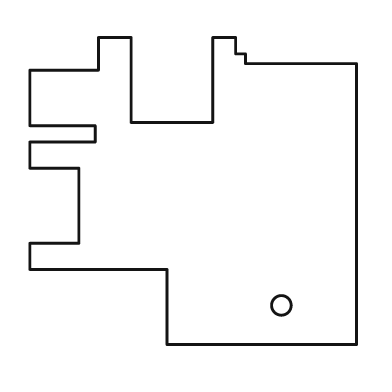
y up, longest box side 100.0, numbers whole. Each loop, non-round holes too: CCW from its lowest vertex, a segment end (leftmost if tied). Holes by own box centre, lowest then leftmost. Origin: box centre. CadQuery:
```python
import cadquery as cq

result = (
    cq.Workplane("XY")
    .moveTo(-8.0, -47.0)
    .lineTo(50.0, -47.0)
    .lineTo(50.0, 39.0)
    .lineTo(16.0, 39.0)
    .lineTo(16.0, 42.0)
    .lineTo(13.0, 42.0)
    .lineTo(13.0, 47.0)
    .lineTo(6.0, 47.0)
    .lineTo(6.0, 21.0)
    .lineTo(-19.0, 21.0)
    .lineTo(-19.0, 47.0)
    .lineTo(-29.0, 47.0)
    .lineTo(-29.0, 37.0)
    .lineTo(-50.0, 37.0)
    .lineTo(-50.0, 20.0)
    .lineTo(-30.0, 20.0)
    .lineTo(-30.0, 15.0)
    .lineTo(-50.0, 15.0)
    .lineTo(-50.0, 7.0)
    .lineTo(-35.0, 7.0)
    .lineTo(-35.0, -16.0)
    .lineTo(-50.0, -16.0)
    .lineTo(-50.0, -24.0)
    .lineTo(-8.0, -24.0)
    .close()
    .moveTo(27.0, -35.0)
    .circle(3.0)
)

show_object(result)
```